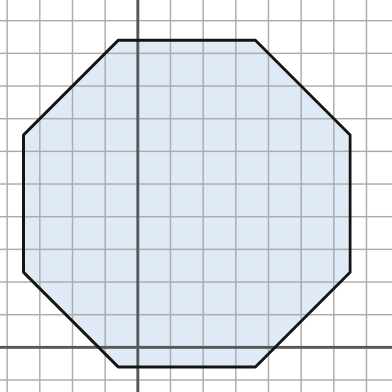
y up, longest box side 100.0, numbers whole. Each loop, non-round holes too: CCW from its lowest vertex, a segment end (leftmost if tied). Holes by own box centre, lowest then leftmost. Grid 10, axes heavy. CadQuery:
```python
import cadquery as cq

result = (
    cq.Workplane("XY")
    .moveTo(-6.0, -6.0)
    .lineTo(36.0, -6.0)
    .lineTo(65.0, 23.0)
    .lineTo(65.0, 65.0)
    .lineTo(36.0, 94.0)
    .lineTo(-6.0, 94.0)
    .lineTo(-35.0, 65.0)
    .lineTo(-35.0, 23.0)
    .close()
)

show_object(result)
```